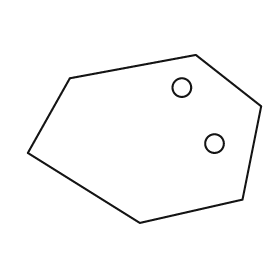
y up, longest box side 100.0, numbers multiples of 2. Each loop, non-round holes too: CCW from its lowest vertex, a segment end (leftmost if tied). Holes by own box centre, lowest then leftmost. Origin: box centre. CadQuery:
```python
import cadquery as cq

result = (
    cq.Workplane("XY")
    .moveTo(-2.0, -36.0)
    .lineTo(42.0, -26.0)
    .lineTo(50.0, 14.0)
    .lineTo(22.0, 36.0)
    .lineTo(-32.0, 26.0)
    .lineTo(-50.0, -6.0)
    .close()
    .moveTo(30.0, -2.0)
    .circle(4.0)
    .moveTo(16.0, 22.0)
    .circle(4.0)
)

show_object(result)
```